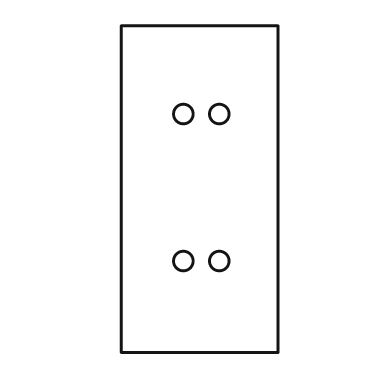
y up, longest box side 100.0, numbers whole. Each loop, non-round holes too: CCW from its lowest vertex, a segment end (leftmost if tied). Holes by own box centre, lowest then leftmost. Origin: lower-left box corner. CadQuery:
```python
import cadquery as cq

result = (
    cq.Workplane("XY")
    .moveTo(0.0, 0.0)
    .lineTo(48.0, 0.0)
    .lineTo(48.0, 100.0)
    .lineTo(0.0, 100.0)
    .close()
    .moveTo(19.0, 28.0)
    .circle(3.0)
    .moveTo(30.0, 28.0)
    .circle(3.0)
    .moveTo(19.0, 73.0)
    .circle(3.0)
    .moveTo(30.0, 73.0)
    .circle(3.0)
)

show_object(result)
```